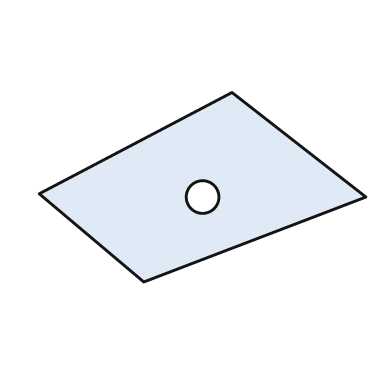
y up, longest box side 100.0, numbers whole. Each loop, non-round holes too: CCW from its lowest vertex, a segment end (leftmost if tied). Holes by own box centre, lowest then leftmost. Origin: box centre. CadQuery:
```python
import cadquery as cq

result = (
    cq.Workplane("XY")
    .moveTo(-18.0, -29.0)
    .lineTo(50.0, -3.0)
    .lineTo(9.0, 29.0)
    .lineTo(-50.0, -2.0)
    .close()
    .moveTo(0.0, -3.0)
    .circle(5.0)
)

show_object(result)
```